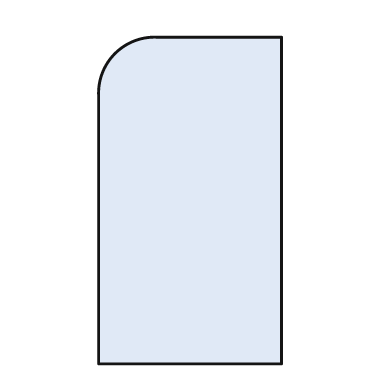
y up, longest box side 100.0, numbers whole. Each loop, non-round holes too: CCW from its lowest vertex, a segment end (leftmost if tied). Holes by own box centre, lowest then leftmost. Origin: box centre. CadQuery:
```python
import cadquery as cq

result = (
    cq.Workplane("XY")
    .moveTo(-28.0, -50.0)
    .lineTo(28.0, -50.0)
    .lineTo(28.0, 50.0)
    .lineTo(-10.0, 50.0)
    .threePointArc((-23.0, 45.0), (-28.0, 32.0))
    .close()
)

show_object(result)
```